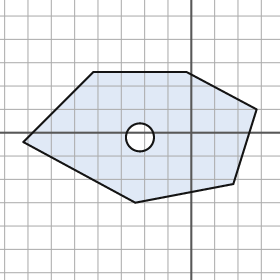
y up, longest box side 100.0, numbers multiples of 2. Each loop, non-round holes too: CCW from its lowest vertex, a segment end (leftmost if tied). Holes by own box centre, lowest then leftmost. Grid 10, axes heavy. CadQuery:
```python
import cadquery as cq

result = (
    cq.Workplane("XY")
    .moveTo(-24.0, -30.0)
    .lineTo(18.0, -22.0)
    .lineTo(28.0, 10.0)
    .lineTo(-2.0, 26.0)
    .lineTo(-42.0, 26.0)
    .lineTo(-72.0, -4.0)
    .close()
    .moveTo(-22.0, -2.0)
    .circle(6.0)
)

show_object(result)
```